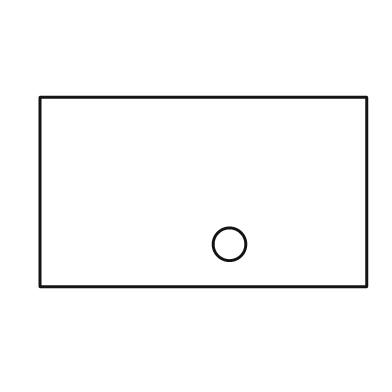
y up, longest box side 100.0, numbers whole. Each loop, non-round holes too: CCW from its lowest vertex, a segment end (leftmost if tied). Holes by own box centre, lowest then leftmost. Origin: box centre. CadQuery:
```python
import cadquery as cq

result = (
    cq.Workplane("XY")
    .moveTo(-50.0, -29.0)
    .lineTo(50.0, -29.0)
    .lineTo(50.0, 29.0)
    .lineTo(-50.0, 29.0)
    .close()
    .moveTo(8.0, -16.0)
    .circle(5.0)
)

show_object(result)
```